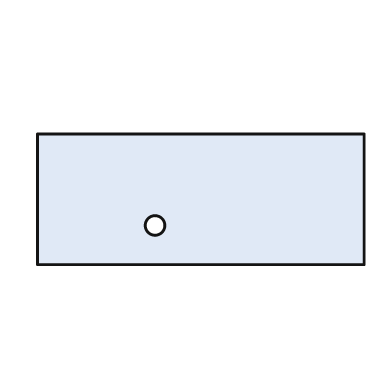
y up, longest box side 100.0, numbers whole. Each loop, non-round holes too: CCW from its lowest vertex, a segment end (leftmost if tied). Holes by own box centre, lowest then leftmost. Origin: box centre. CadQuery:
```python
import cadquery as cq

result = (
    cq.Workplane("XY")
    .moveTo(-50.0, -20.0)
    .lineTo(50.0, -20.0)
    .lineTo(50.0, 20.0)
    .lineTo(-50.0, 20.0)
    .close()
    .moveTo(-14.0, -8.0)
    .circle(3.0)
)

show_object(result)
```